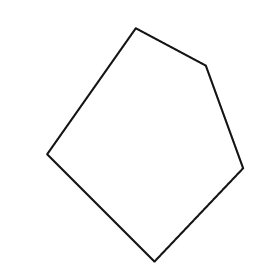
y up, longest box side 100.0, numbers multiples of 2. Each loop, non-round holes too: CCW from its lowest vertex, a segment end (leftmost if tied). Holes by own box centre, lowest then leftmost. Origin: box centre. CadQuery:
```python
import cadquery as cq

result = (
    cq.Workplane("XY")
    .moveTo(4.0, -50.0)
    .lineTo(42.0, -10.0)
    .lineTo(26.0, 34.0)
    .lineTo(-4.0, 50.0)
    .lineTo(-42.0, -4.0)
    .close()
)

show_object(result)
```